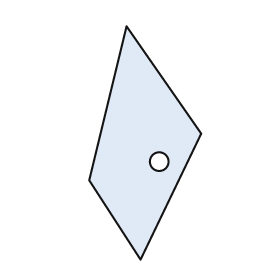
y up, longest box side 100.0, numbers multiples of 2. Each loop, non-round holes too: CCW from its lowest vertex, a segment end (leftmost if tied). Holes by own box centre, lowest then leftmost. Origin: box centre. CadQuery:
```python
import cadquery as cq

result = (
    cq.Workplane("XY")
    .moveTo(-2.0, -50.0)
    .lineTo(24.0, 4.0)
    .lineTo(-8.0, 50.0)
    .lineTo(-24.0, -16.0)
    .close()
    .moveTo(6.0, -8.0)
    .circle(4.0)
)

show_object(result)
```